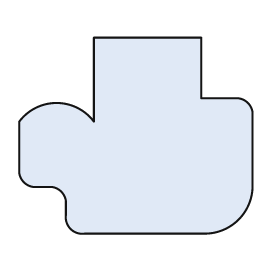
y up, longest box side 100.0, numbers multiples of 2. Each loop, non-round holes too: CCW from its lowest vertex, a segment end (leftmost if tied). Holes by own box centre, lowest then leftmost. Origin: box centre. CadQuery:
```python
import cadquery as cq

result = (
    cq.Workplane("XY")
    .moveTo(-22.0, -42.0)
    .lineTo(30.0, -42.0)
    .threePointArc((44.0, -36.0), (50.0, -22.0))
    .lineTo(50.0, 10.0)
    .threePointArc((48.0, 14.0), (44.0, 16.0))
    .lineTo(28.0, 16.0)
    .lineTo(28.0, 42.0)
    .lineTo(-18.0, 42.0)
    .lineTo(-18.0, 6.0)
    .threePointArc((-34.0, 14.0), (-50.0, 6.0))
    .lineTo(-50.0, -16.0)
    .threePointArc((-48.0, -20.0), (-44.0, -22.0))
    .lineTo(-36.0, -22.0)
    .threePointArc((-32.0, -24.0), (-30.0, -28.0))
    .lineTo(-30.0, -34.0)
    .threePointArc((-28.0, -40.0), (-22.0, -42.0))
    .close()
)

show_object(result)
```